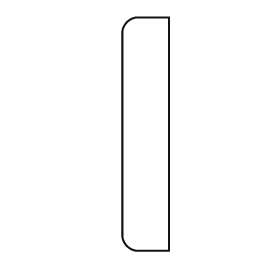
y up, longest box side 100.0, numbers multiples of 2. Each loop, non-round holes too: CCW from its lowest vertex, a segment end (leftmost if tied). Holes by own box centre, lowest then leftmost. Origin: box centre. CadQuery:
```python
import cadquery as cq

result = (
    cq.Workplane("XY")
    .moveTo(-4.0, -50.0)
    .lineTo(10.0, -50.0)
    .lineTo(10.0, 50.0)
    .lineTo(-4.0, 50.0)
    .threePointArc((-8.0, 48.0), (-10.0, 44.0))
    .lineTo(-10.0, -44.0)
    .threePointArc((-8.0, -48.0), (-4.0, -50.0))
    .close()
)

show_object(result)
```